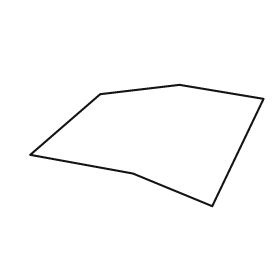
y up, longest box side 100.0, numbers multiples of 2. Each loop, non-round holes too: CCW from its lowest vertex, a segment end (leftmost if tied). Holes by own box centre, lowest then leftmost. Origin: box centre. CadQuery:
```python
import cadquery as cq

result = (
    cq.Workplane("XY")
    .moveTo(28.0, -26.0)
    .lineTo(50.0, 20.0)
    .lineTo(14.0, 26.0)
    .lineTo(-20.0, 22.0)
    .lineTo(-50.0, -4.0)
    .lineTo(-6.0, -12.0)
    .close()
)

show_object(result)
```